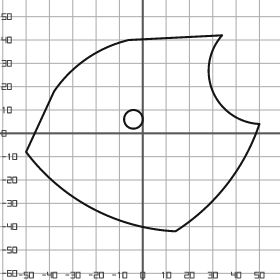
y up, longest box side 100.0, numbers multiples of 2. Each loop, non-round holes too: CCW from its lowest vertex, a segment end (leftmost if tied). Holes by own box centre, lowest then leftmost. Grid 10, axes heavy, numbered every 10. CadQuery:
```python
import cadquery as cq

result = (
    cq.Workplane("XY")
    .moveTo(14.0, -42.0)
    .threePointArc((36.0, -22.0), (50.0, 4.0))
    .threePointArc((30.0, 18.0), (34.0, 42.0))
    .lineTo(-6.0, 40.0)
    .threePointArc((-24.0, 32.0), (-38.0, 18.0))
    .lineTo(-50.0, -8.0)
    .threePointArc((-22.0, -32.0), (14.0, -42.0))
    .close()
    .moveTo(-4.0, 6.0)
    .circle(4.0)
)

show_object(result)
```